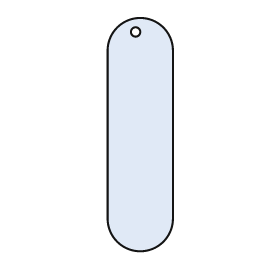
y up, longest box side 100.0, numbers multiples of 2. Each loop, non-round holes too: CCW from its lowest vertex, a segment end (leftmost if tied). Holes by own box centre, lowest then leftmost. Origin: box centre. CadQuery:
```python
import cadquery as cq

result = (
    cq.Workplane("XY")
    .moveTo(-14.0, -36.0)
    .threePointArc((0.0, -50.0), (14.0, -36.0))
    .lineTo(14.0, 36.0)
    .threePointArc((0.0, 50.0), (-14.0, 36.0))
    .close()
    .moveTo(-2.0, 44.0)
    .circle(2.0)
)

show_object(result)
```